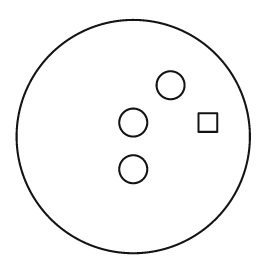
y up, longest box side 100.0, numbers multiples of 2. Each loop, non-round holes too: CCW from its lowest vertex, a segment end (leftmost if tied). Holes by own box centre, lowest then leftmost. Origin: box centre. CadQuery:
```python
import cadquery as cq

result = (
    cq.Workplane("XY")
    .moveTo(0.0, 0.0)
    .circle(50.0)
    .moveTo(0.0, -14.0)
    .circle(6.0)
    .moveTo(0.0, 6.0)
    .circle(6.0)
    .moveTo(28.0, 2.0)
    .lineTo(36.0, 2.0)
    .lineTo(36.0, 10.0)
    .lineTo(28.0, 10.0)
    .close()
    .moveTo(16.0, 22.0)
    .circle(6.0)
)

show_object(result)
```